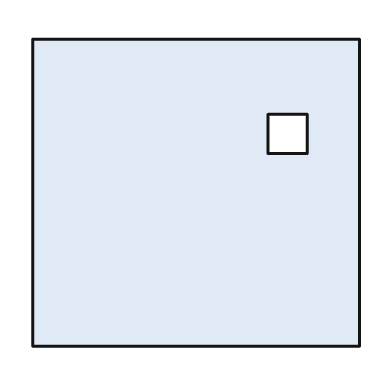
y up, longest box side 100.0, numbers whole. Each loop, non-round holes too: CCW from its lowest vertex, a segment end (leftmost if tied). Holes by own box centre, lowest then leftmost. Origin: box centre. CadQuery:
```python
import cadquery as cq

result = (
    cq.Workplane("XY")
    .moveTo(-50.0, -47.0)
    .lineTo(50.0, -47.0)
    .lineTo(50.0, 47.0)
    .lineTo(-50.0, 47.0)
    .close()
    .moveTo(22.0, 12.0)
    .lineTo(34.0, 12.0)
    .lineTo(34.0, 24.0)
    .lineTo(22.0, 24.0)
    .close()
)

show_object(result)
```